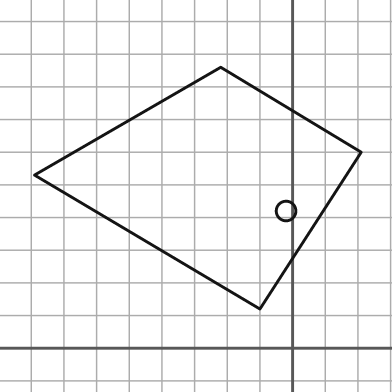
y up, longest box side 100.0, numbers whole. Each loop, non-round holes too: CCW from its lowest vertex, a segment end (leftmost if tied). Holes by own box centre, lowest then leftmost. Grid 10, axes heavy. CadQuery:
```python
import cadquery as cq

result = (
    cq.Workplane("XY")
    .moveTo(-10.0, 12.0)
    .lineTo(21.0, 60.0)
    .lineTo(-22.0, 86.0)
    .lineTo(-79.0, 53.0)
    .close()
    .moveTo(-2.0, 42.0)
    .circle(3.0)
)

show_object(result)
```